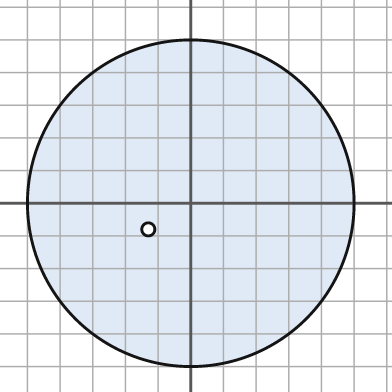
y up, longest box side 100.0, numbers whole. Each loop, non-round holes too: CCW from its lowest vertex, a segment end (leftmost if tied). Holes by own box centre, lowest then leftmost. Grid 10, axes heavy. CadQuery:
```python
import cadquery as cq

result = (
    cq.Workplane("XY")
    .moveTo(0.0, 0.0)
    .circle(50.0)
    .moveTo(-13.0, -8.0)
    .circle(2.0)
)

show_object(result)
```